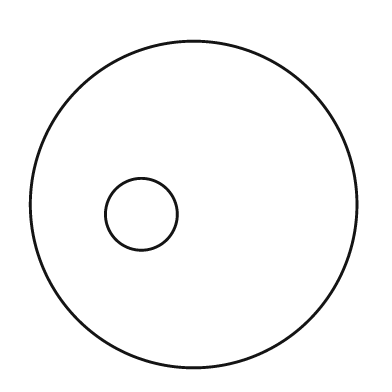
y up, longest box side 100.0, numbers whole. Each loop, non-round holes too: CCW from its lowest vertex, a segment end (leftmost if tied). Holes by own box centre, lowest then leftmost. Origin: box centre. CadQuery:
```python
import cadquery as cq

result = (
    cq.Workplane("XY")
    .moveTo(0.0, 0.0)
    .circle(50.0)
    .moveTo(-16.0, -3.0)
    .circle(11.0)
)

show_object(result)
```